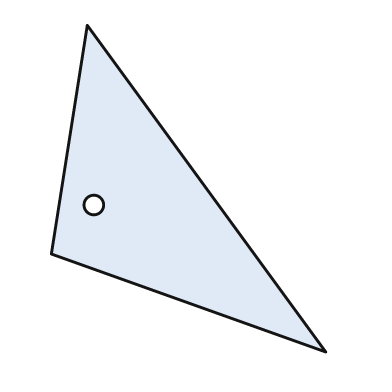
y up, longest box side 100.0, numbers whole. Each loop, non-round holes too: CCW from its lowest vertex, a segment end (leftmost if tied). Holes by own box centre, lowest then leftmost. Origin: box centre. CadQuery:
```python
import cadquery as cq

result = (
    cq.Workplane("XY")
    .moveTo(42.0, -50.0)
    .lineTo(-31.0, 50.0)
    .lineTo(-42.0, -20.0)
    .close()
    .moveTo(-29.0, -5.0)
    .circle(3.0)
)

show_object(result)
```